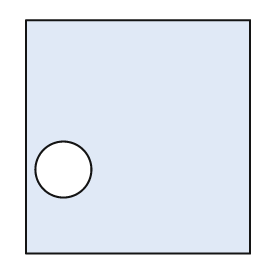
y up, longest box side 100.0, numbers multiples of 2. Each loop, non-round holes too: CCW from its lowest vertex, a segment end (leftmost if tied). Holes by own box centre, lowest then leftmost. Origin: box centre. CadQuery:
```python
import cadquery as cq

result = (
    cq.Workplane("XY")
    .moveTo(-48.0, -50.0)
    .lineTo(48.0, -50.0)
    .lineTo(48.0, 50.0)
    .lineTo(-48.0, 50.0)
    .close()
    .moveTo(-32.0, -14.0)
    .circle(12.0)
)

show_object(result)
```